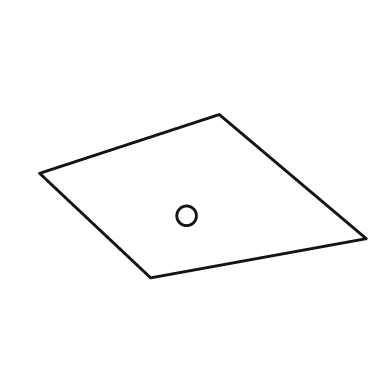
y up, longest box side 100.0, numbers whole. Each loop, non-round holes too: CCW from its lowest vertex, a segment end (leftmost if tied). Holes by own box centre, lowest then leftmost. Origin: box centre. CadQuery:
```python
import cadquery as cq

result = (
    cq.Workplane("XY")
    .moveTo(-16.0, -25.0)
    .lineTo(50.0, -13.0)
    .lineTo(5.0, 25.0)
    .lineTo(-50.0, 7.0)
    .close()
    .moveTo(-5.0, -6.0)
    .circle(3.0)
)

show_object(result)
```